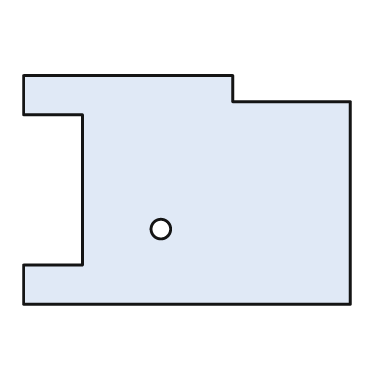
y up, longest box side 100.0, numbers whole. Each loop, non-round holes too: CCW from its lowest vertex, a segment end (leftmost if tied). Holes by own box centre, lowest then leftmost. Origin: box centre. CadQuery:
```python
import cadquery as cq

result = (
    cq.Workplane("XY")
    .moveTo(-50.0, -35.0)
    .lineTo(50.0, -35.0)
    .lineTo(50.0, 27.0)
    .lineTo(14.0, 27.0)
    .lineTo(14.0, 35.0)
    .lineTo(-50.0, 35.0)
    .lineTo(-50.0, 23.0)
    .lineTo(-32.0, 23.0)
    .lineTo(-32.0, -23.0)
    .lineTo(-50.0, -23.0)
    .close()
    .moveTo(-8.0, -12.0)
    .circle(3.0)
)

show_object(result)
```